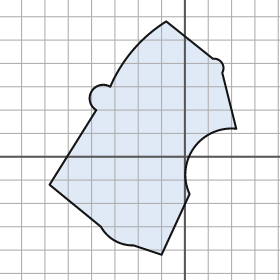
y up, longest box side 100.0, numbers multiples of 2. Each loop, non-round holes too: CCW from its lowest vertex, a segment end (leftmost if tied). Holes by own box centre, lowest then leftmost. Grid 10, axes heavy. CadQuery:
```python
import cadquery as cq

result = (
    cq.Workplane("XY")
    .moveTo(-10.0, -42.0)
    .lineTo(2.0, -16.0)
    .threePointArc((4.0, 4.0), (22.0, 12.0))
    .lineTo(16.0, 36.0)
    .threePointArc((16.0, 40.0), (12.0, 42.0))
    .lineTo(-8.0, 58.0)
    .threePointArc((-22.0, 46.0), (-32.0, 30.0))
    .threePointArc((-40.0, 28.0), (-38.0, 20.0))
    .lineTo(-58.0, -12.0)
    .lineTo(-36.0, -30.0)
    .threePointArc((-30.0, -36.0), (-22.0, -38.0))
    .close()
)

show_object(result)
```